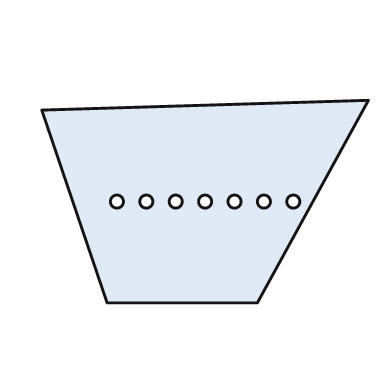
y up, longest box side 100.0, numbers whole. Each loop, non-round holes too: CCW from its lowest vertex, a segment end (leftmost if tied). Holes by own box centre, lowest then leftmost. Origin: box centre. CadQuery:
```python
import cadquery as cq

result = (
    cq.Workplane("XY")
    .moveTo(-30.0, -31.0)
    .lineTo(16.0, -31.0)
    .lineTo(50.0, 31.0)
    .lineTo(-50.0, 28.0)
    .close()
    .moveTo(-27.0, 0.0)
    .circle(2.0)
    .moveTo(-18.0, 0.0)
    .circle(2.0)
    .moveTo(-9.0, 0.0)
    .circle(2.0)
    .moveTo(0.0, 0.0)
    .circle(2.0)
    .moveTo(9.0, 0.0)
    .circle(2.0)
    .moveTo(18.0, 0.0)
    .circle(2.0)
    .moveTo(27.0, 0.0)
    .circle(2.0)
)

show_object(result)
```